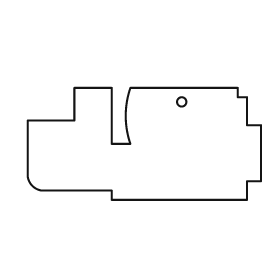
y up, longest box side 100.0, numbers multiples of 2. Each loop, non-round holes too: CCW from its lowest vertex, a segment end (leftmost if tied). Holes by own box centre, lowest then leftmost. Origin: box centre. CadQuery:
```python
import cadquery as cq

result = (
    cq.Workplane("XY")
    .moveTo(-14.0, -24.0)
    .lineTo(44.0, -24.0)
    .lineTo(44.0, -16.0)
    .lineTo(50.0, -16.0)
    .lineTo(50.0, 8.0)
    .lineTo(44.0, 8.0)
    .lineTo(44.0, 20.0)
    .lineTo(40.0, 20.0)
    .lineTo(40.0, 24.0)
    .lineTo(-6.0, 24.0)
    .threePointArc((-8.0, 12.0), (-6.0, 0.0))
    .lineTo(-14.0, 0.0)
    .lineTo(-14.0, 24.0)
    .lineTo(-30.0, 24.0)
    .lineTo(-30.0, 10.0)
    .lineTo(-50.0, 10.0)
    .lineTo(-50.0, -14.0)
    .threePointArc((-48.0, -18.0), (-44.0, -20.0))
    .lineTo(-14.0, -20.0)
    .close()
    .moveTo(16.0, 18.0)
    .circle(2.0)
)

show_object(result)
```